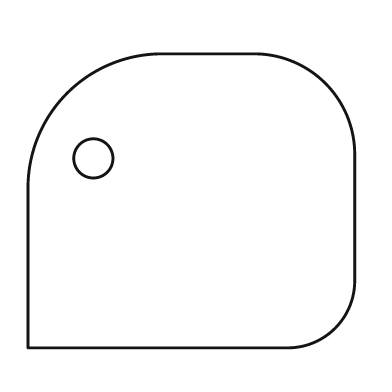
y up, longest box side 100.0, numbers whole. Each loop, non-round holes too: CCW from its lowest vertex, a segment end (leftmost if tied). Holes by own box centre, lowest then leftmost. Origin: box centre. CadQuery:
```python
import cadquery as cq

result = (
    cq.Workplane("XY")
    .moveTo(-50.0, -45.0)
    .lineTo(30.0, -45.0)
    .threePointArc((44.0, -39.0), (50.0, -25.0))
    .lineTo(50.0, 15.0)
    .threePointArc((41.0, 36.0), (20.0, 45.0))
    .lineTo(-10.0, 45.0)
    .threePointArc((-38.0, 33.0), (-50.0, 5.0))
    .close()
    .moveTo(-30.0, 13.0)
    .circle(6.0)
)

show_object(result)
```